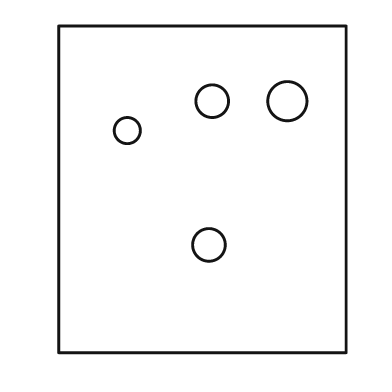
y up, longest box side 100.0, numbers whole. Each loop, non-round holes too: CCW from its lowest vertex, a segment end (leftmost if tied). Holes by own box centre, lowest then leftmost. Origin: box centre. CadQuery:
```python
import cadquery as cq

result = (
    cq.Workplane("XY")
    .moveTo(-44.0, -50.0)
    .lineTo(44.0, -50.0)
    .lineTo(44.0, 50.0)
    .lineTo(-44.0, 50.0)
    .close()
    .moveTo(2.0, -17.0)
    .circle(5.0)
    .moveTo(-23.0, 18.0)
    .circle(4.0)
    .moveTo(3.0, 27.0)
    .circle(5.0)
    .moveTo(26.0, 27.0)
    .circle(6.0)
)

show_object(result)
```